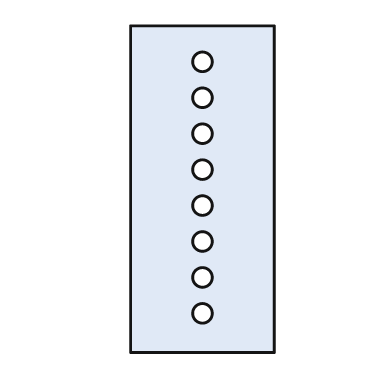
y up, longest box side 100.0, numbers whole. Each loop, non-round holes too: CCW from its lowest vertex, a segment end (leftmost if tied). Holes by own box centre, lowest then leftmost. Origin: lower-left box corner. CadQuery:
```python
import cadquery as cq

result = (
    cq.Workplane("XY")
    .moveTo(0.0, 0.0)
    .lineTo(44.0, 0.0)
    .lineTo(44.0, 100.0)
    .lineTo(0.0, 100.0)
    .close()
    .moveTo(22.0, 12.0)
    .circle(3.0)
    .moveTo(22.0, 23.0)
    .circle(3.0)
    .moveTo(22.0, 34.0)
    .circle(3.0)
    .moveTo(22.0, 45.0)
    .circle(3.0)
    .moveTo(22.0, 56.0)
    .circle(3.0)
    .moveTo(22.0, 67.0)
    .circle(3.0)
    .moveTo(22.0, 78.0)
    .circle(3.0)
    .moveTo(22.0, 89.0)
    .circle(3.0)
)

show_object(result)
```